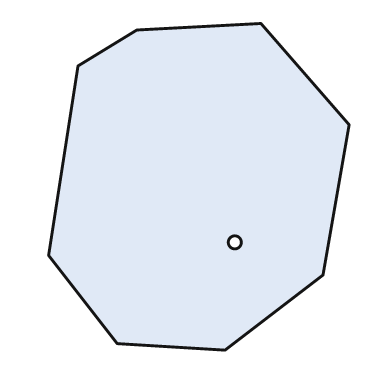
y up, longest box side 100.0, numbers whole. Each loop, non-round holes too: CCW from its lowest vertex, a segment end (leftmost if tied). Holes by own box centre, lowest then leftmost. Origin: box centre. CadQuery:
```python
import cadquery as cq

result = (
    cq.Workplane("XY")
    .moveTo(8.0, -50.0)
    .lineTo(38.0, -27.0)
    .lineTo(46.0, 19.0)
    .lineTo(19.0, 50.0)
    .lineTo(-19.0, 48.0)
    .lineTo(-37.0, 37.0)
    .lineTo(-46.0, -21.0)
    .lineTo(-25.0, -48.0)
    .close()
    .moveTo(11.0, -17.0)
    .circle(2.0)
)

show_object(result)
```